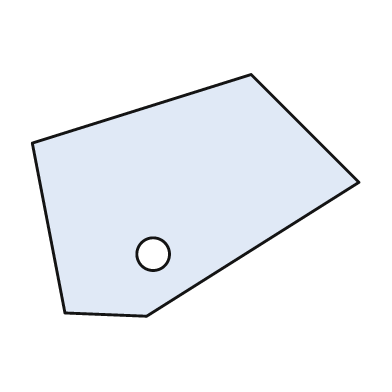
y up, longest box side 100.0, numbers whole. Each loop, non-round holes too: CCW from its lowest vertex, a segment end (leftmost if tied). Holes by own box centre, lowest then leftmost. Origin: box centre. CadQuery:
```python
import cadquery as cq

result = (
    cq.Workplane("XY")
    .moveTo(-15.0, -37.0)
    .lineTo(50.0, 4.0)
    .lineTo(17.0, 37.0)
    .lineTo(-50.0, 16.0)
    .lineTo(-40.0, -36.0)
    .close()
    .moveTo(-13.0, -18.0)
    .circle(5.0)
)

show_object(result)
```